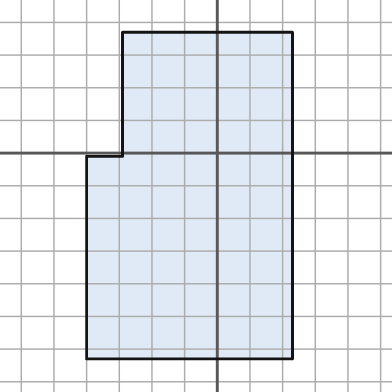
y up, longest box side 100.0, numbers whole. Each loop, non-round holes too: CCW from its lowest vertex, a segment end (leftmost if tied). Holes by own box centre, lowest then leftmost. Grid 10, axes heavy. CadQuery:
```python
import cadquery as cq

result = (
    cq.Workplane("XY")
    .moveTo(-40.0, -63.0)
    .lineTo(23.0, -63.0)
    .lineTo(23.0, 37.0)
    .lineTo(-29.0, 37.0)
    .lineTo(-29.0, -1.0)
    .lineTo(-40.0, -1.0)
    .close()
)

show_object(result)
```